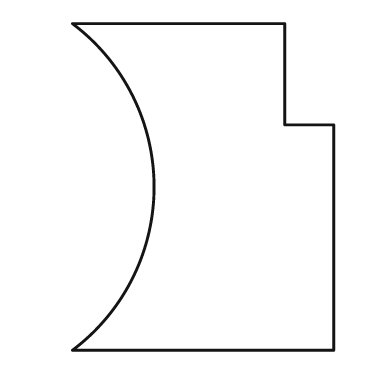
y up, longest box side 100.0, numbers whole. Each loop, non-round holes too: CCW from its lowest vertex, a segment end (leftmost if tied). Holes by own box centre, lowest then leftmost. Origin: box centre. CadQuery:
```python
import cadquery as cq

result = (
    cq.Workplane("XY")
    .moveTo(-40.0, -50.0)
    .lineTo(40.0, -50.0)
    .lineTo(40.0, 19.0)
    .lineTo(25.0, 19.0)
    .lineTo(25.0, 50.0)
    .lineTo(-40.0, 50.0)
    .threePointArc((-15.0, 0.0), (-40.0, -50.0))
    .close()
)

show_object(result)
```